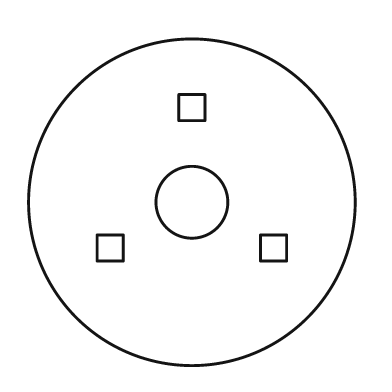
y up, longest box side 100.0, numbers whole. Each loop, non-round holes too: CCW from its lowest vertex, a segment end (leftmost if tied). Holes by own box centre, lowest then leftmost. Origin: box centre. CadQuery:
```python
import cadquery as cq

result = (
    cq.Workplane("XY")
    .moveTo(0.0, 0.0)
    .circle(50.0)
    .moveTo(-29.0, -18.0)
    .lineTo(-21.0, -18.0)
    .lineTo(-21.0, -10.0)
    .lineTo(-29.0, -10.0)
    .close()
    .moveTo(21.0, -18.0)
    .lineTo(29.0, -18.0)
    .lineTo(29.0, -10.0)
    .lineTo(21.0, -10.0)
    .close()
    .moveTo(0.0, 0.0)
    .circle(11.0)
    .moveTo(-4.0, 25.0)
    .lineTo(4.0, 25.0)
    .lineTo(4.0, 33.0)
    .lineTo(-4.0, 33.0)
    .close()
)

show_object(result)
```